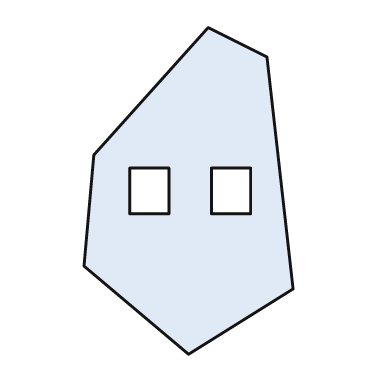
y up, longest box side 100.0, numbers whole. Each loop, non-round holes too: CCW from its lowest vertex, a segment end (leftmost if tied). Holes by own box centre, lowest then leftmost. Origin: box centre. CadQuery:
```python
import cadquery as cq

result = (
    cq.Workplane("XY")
    .moveTo(0.0, -50.0)
    .lineTo(32.0, -30.0)
    .lineTo(24.0, 41.0)
    .lineTo(6.0, 50.0)
    .lineTo(-29.0, 11.0)
    .lineTo(-32.0, -23.0)
    .close()
    .moveTo(-18.0, -7.0)
    .lineTo(-6.0, -7.0)
    .lineTo(-6.0, 7.0)
    .lineTo(-18.0, 7.0)
    .close()
    .moveTo(7.0, -7.0)
    .lineTo(19.0, -7.0)
    .lineTo(19.0, 7.0)
    .lineTo(7.0, 7.0)
    .close()
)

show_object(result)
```